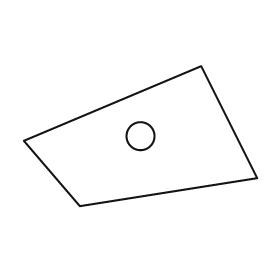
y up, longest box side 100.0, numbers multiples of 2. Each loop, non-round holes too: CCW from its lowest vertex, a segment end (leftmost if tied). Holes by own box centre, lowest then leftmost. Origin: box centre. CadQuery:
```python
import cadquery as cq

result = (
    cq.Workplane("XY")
    .moveTo(-26.0, -30.0)
    .lineTo(50.0, -18.0)
    .lineTo(26.0, 30.0)
    .lineTo(-50.0, -2.0)
    .close()
    .moveTo(0.0, 0.0)
    .circle(6.0)
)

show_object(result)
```